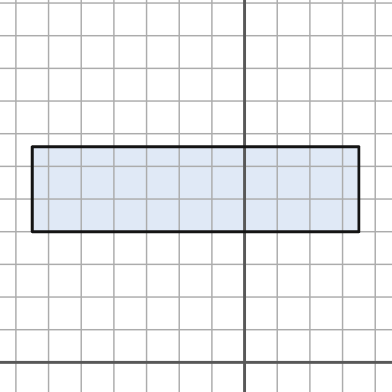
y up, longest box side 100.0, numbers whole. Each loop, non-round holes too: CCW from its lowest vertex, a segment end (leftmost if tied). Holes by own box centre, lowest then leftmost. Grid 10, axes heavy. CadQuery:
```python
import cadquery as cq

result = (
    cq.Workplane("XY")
    .moveTo(-65.0, 40.0)
    .lineTo(35.0, 40.0)
    .lineTo(35.0, 66.0)
    .lineTo(-65.0, 66.0)
    .close()
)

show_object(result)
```